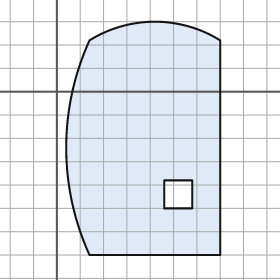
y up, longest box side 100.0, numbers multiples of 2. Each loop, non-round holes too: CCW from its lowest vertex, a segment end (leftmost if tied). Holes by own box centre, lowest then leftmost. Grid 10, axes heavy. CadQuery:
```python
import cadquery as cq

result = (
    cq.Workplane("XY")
    .moveTo(14.0, -70.0)
    .lineTo(70.0, -70.0)
    .lineTo(70.0, 22.0)
    .threePointArc((42.0, 30.0), (14.0, 22.0))
    .threePointArc((4.0, -24.0), (14.0, -70.0))
    .close()
    .moveTo(46.0, -50.0)
    .lineTo(58.0, -50.0)
    .lineTo(58.0, -38.0)
    .lineTo(46.0, -38.0)
    .close()
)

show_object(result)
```